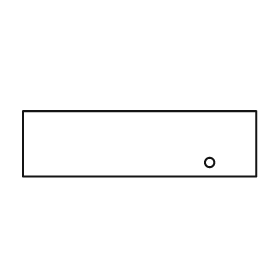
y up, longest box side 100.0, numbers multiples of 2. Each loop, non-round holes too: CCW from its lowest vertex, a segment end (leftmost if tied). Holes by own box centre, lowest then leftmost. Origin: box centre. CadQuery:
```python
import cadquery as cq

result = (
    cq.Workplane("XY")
    .moveTo(-50.0, -14.0)
    .lineTo(50.0, -14.0)
    .lineTo(50.0, 14.0)
    .lineTo(-50.0, 14.0)
    .close()
    .moveTo(30.0, -8.0)
    .circle(2.0)
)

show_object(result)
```